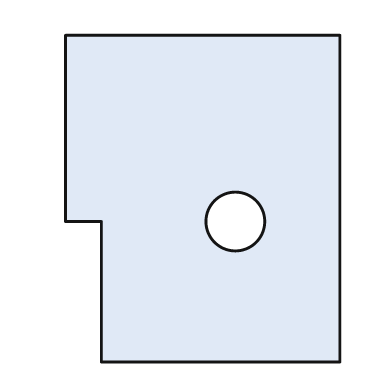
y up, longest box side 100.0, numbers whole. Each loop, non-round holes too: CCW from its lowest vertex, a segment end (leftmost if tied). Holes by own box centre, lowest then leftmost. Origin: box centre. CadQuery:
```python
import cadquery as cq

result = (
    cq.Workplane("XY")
    .moveTo(-31.0, -50.0)
    .lineTo(42.0, -50.0)
    .lineTo(42.0, 50.0)
    .lineTo(-42.0, 50.0)
    .lineTo(-42.0, -7.0)
    .lineTo(-31.0, -7.0)
    .close()
    .moveTo(10.0, -7.0)
    .circle(9.0)
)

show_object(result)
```